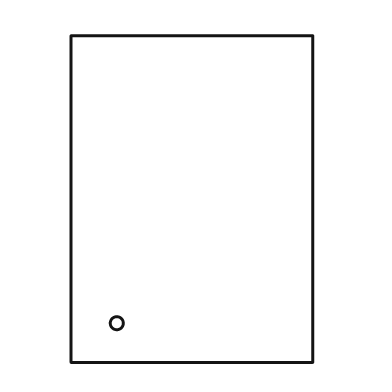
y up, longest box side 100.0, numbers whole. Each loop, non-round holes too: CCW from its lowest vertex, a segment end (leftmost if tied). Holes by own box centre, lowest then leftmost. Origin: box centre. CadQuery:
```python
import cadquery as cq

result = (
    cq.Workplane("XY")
    .moveTo(-37.0, -50.0)
    .lineTo(37.0, -50.0)
    .lineTo(37.0, 50.0)
    .lineTo(-37.0, 50.0)
    .close()
    .moveTo(-23.0, -38.0)
    .circle(2.0)
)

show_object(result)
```